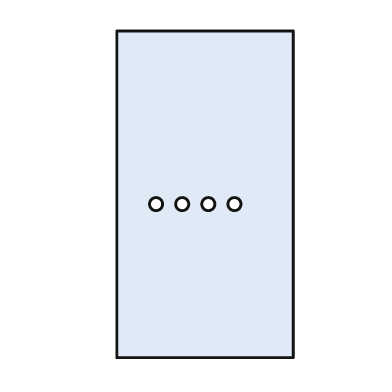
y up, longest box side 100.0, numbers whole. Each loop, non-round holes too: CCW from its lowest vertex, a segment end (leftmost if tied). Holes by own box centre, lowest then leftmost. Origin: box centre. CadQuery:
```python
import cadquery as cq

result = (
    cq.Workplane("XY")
    .moveTo(-27.0, -50.0)
    .lineTo(27.0, -50.0)
    .lineTo(27.0, 50.0)
    .lineTo(-27.0, 50.0)
    .close()
    .moveTo(-15.0, -3.0)
    .circle(2.0)
    .moveTo(-7.0, -3.0)
    .circle(2.0)
    .moveTo(1.0, -3.0)
    .circle(2.0)
    .moveTo(9.0, -3.0)
    .circle(2.0)
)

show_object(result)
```